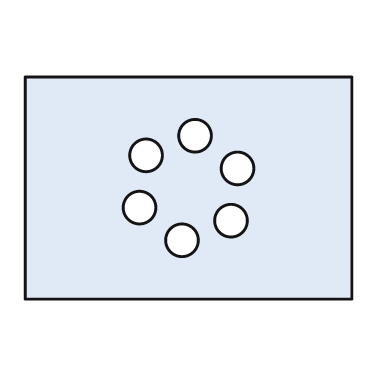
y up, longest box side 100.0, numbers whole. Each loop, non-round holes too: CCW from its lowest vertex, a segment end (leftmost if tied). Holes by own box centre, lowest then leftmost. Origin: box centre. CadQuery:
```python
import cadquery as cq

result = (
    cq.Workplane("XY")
    .moveTo(-50.0, -34.0)
    .lineTo(50.0, -34.0)
    .lineTo(50.0, 34.0)
    .lineTo(-50.0, 34.0)
    .close()
    .moveTo(-2.0, -16.0)
    .circle(5.0)
    .moveTo(13.0, -10.0)
    .circle(5.0)
    .moveTo(-15.0, -6.0)
    .circle(5.0)
    .moveTo(15.0, 6.0)
    .circle(5.0)
    .moveTo(-13.0, 10.0)
    .circle(5.0)
    .moveTo(2.0, 16.0)
    .circle(5.0)
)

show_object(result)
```